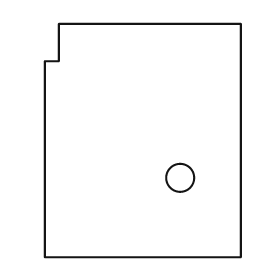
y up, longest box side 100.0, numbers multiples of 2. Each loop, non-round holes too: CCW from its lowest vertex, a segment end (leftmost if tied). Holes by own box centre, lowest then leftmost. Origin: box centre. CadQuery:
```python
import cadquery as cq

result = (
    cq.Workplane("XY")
    .moveTo(-42.0, -50.0)
    .lineTo(42.0, -50.0)
    .lineTo(42.0, 50.0)
    .lineTo(-36.0, 50.0)
    .lineTo(-36.0, 34.0)
    .lineTo(-42.0, 34.0)
    .close()
    .moveTo(16.0, -16.0)
    .circle(6.0)
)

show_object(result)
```